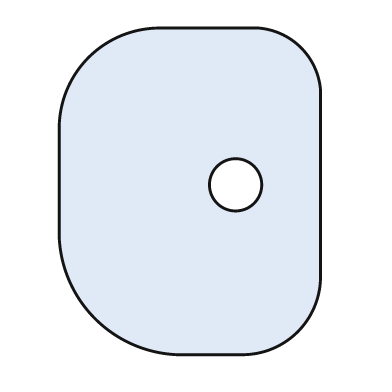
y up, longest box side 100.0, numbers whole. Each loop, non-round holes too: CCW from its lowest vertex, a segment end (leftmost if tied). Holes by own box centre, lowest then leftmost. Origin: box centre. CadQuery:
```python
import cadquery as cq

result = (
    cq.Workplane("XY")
    .moveTo(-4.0, -50.0)
    .lineTo(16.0, -50.0)
    .threePointArc((33.0, -43.0), (40.0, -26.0))
    .lineTo(40.0, 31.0)
    .threePointArc((34.0, 44.0), (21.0, 50.0))
    .lineTo(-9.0, 50.0)
    .threePointArc((-31.0, 41.0), (-40.0, 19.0))
    .lineTo(-40.0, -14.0)
    .threePointArc((-29.0, -39.0), (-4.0, -50.0))
    .close()
    .moveTo(14.0, 2.0)
    .circle(8.0)
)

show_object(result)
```